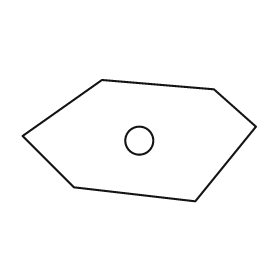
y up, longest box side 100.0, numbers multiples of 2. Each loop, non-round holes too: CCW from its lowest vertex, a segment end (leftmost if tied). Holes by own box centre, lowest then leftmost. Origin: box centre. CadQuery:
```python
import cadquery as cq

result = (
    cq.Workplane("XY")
    .moveTo(24.0, -26.0)
    .lineTo(50.0, 6.0)
    .lineTo(32.0, 22.0)
    .lineTo(-16.0, 26.0)
    .lineTo(-50.0, 2.0)
    .lineTo(-28.0, -20.0)
    .close()
    .moveTo(0.0, 0.0)
    .circle(6.0)
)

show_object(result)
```